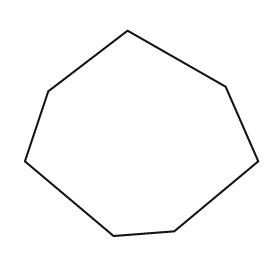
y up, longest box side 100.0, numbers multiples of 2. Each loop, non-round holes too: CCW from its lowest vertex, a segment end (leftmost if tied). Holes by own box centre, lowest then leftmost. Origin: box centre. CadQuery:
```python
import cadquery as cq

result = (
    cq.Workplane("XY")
    .moveTo(-12.0, -44.0)
    .lineTo(14.0, -42.0)
    .lineTo(50.0, -12.0)
    .lineTo(36.0, 20.0)
    .lineTo(-6.0, 44.0)
    .lineTo(-40.0, 18.0)
    .lineTo(-50.0, -12.0)
    .close()
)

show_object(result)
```